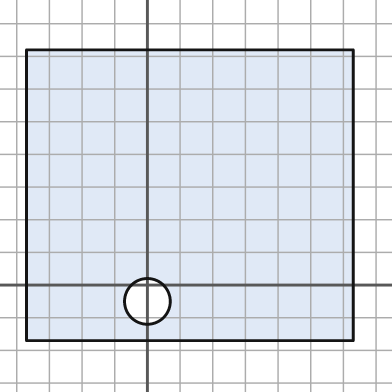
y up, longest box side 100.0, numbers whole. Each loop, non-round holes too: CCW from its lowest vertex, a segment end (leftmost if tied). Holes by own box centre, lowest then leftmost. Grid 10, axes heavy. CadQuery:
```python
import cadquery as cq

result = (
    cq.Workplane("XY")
    .moveTo(-37.0, -17.0)
    .lineTo(63.0, -17.0)
    .lineTo(63.0, 72.0)
    .lineTo(-37.0, 72.0)
    .close()
    .moveTo(0.0, -5.0)
    .circle(7.0)
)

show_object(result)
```